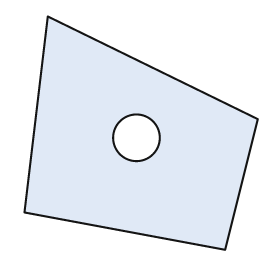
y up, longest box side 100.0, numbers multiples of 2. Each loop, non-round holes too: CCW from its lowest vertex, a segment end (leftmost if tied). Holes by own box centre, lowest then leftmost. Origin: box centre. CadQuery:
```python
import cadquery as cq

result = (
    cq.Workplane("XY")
    .moveTo(36.0, -50.0)
    .lineTo(50.0, 6.0)
    .lineTo(-40.0, 50.0)
    .lineTo(-50.0, -34.0)
    .close()
    .moveTo(-2.0, -2.0)
    .circle(10.0)
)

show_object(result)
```